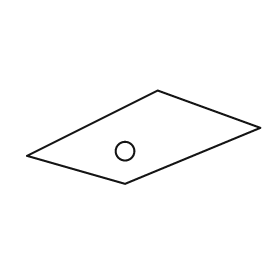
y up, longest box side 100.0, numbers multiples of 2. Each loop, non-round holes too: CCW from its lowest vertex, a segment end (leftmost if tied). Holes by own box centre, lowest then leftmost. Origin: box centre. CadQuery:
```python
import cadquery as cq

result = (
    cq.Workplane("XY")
    .moveTo(-8.0, -20.0)
    .lineTo(50.0, 4.0)
    .lineTo(6.0, 20.0)
    .lineTo(-50.0, -8.0)
    .close()
    .moveTo(-8.0, -6.0)
    .circle(4.0)
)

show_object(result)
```